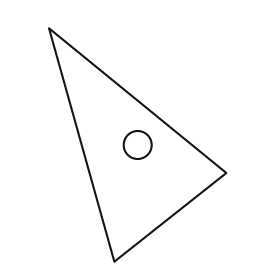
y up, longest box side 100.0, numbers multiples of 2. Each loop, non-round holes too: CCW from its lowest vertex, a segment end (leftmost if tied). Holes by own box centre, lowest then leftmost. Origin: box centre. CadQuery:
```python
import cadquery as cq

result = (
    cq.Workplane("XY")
    .moveTo(-10.0, -50.0)
    .lineTo(38.0, -12.0)
    .lineTo(-38.0, 50.0)
    .close()
    .moveTo(0.0, 0.0)
    .circle(6.0)
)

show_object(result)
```